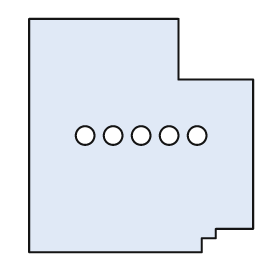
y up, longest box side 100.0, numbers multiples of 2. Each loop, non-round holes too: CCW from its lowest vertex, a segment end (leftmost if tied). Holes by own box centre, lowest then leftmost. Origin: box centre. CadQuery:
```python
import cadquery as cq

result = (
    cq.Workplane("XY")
    .moveTo(-48.0, -50.0)
    .lineTo(26.0, -50.0)
    .lineTo(26.0, -44.0)
    .lineTo(32.0, -44.0)
    .lineTo(32.0, -40.0)
    .lineTo(48.0, -40.0)
    .lineTo(48.0, 24.0)
    .lineTo(16.0, 24.0)
    .lineTo(16.0, 50.0)
    .lineTo(-48.0, 50.0)
    .close()
    .moveTo(-24.0, 0.0)
    .circle(4.0)
    .moveTo(-12.0, 0.0)
    .circle(4.0)
    .moveTo(0.0, 0.0)
    .circle(4.0)
    .moveTo(12.0, 0.0)
    .circle(4.0)
    .moveTo(24.0, 0.0)
    .circle(4.0)
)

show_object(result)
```